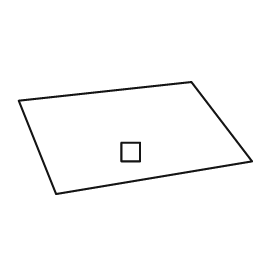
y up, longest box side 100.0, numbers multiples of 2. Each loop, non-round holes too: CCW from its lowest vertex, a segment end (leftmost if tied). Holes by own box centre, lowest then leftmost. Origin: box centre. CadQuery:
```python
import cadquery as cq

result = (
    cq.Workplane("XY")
    .moveTo(-34.0, -24.0)
    .lineTo(50.0, -10.0)
    .lineTo(24.0, 24.0)
    .lineTo(-50.0, 16.0)
    .close()
    .moveTo(-6.0, -10.0)
    .lineTo(2.0, -10.0)
    .lineTo(2.0, -2.0)
    .lineTo(-6.0, -2.0)
    .close()
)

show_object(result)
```